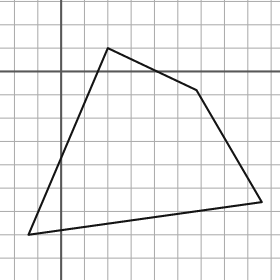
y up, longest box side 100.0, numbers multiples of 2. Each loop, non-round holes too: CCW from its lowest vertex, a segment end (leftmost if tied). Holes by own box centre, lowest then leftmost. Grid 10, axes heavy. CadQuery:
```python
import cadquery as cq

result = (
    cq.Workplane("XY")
    .moveTo(-14.0, -70.0)
    .lineTo(86.0, -56.0)
    .lineTo(58.0, -8.0)
    .lineTo(20.0, 10.0)
    .close()
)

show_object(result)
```